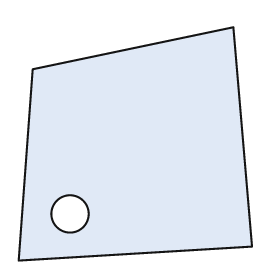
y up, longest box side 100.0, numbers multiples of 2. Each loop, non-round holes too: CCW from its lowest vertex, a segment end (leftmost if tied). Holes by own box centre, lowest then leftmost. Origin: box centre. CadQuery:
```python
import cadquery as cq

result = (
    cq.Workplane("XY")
    .moveTo(-50.0, -50.0)
    .lineTo(50.0, -44.0)
    .lineTo(42.0, 50.0)
    .lineTo(-44.0, 32.0)
    .close()
    .moveTo(-28.0, -30.0)
    .circle(8.0)
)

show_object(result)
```